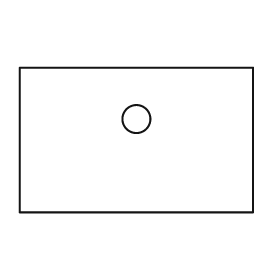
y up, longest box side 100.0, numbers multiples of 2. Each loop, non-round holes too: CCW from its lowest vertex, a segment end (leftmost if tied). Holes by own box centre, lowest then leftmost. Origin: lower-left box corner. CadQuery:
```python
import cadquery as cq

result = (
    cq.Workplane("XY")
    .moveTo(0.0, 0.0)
    .lineTo(100.0, 0.0)
    .lineTo(100.0, 62.0)
    .lineTo(0.0, 62.0)
    .close()
    .moveTo(50.0, 40.0)
    .circle(6.0)
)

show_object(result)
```